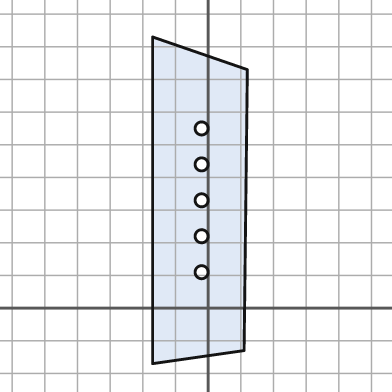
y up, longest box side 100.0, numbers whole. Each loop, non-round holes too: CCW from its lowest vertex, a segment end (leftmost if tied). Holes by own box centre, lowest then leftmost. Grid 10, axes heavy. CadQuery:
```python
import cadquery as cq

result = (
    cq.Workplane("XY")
    .moveTo(-17.0, -17.0)
    .lineTo(11.0, -13.0)
    .lineTo(12.0, 73.0)
    .lineTo(-17.0, 83.0)
    .close()
    .moveTo(-2.0, 11.0)
    .circle(2.0)
    .moveTo(-2.0, 22.0)
    .circle(2.0)
    .moveTo(-2.0, 33.0)
    .circle(2.0)
    .moveTo(-2.0, 44.0)
    .circle(2.0)
    .moveTo(-2.0, 55.0)
    .circle(2.0)
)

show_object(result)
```